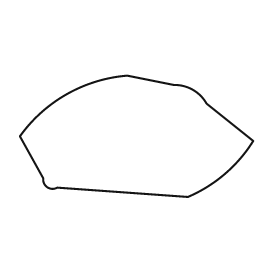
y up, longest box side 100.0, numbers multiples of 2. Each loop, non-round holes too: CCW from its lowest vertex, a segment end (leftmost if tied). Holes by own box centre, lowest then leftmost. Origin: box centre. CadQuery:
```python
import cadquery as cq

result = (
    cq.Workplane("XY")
    .moveTo(22.0, -26.0)
    .threePointArc((38.0, -16.0), (50.0, -2.0))
    .lineTo(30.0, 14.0)
    .threePointArc((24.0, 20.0), (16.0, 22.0))
    .lineTo(-4.0, 26.0)
    .threePointArc((-30.0, 18.0), (-50.0, 0.0))
    .lineTo(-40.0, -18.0)
    .threePointArc((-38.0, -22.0), (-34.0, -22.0))
    .close()
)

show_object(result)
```